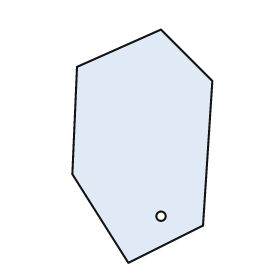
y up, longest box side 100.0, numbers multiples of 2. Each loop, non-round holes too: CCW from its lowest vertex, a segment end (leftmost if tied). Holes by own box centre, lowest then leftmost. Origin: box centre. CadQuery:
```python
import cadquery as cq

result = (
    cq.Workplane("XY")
    .moveTo(-6.0, -50.0)
    .lineTo(26.0, -34.0)
    .lineTo(30.0, 28.0)
    .lineTo(8.0, 50.0)
    .lineTo(-28.0, 34.0)
    .lineTo(-30.0, -12.0)
    .close()
    .moveTo(8.0, -30.0)
    .circle(2.0)
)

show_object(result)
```